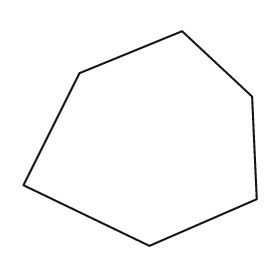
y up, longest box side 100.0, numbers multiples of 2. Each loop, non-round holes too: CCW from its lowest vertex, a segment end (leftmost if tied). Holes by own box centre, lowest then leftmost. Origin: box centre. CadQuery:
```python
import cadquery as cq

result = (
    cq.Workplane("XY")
    .moveTo(4.0, -46.0)
    .lineTo(50.0, -26.0)
    .lineTo(48.0, 18.0)
    .lineTo(18.0, 46.0)
    .lineTo(-26.0, 28.0)
    .lineTo(-50.0, -20.0)
    .close()
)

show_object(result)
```